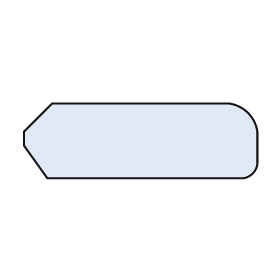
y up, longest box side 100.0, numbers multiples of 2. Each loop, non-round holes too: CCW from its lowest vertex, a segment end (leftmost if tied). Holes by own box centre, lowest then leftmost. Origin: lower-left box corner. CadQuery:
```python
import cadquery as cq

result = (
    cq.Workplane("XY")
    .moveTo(10.0, 0.0)
    .lineTo(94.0, 0.0)
    .threePointArc((98.0, 2.0), (100.0, 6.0))
    .lineTo(100.0, 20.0)
    .threePointArc((96.0, 28.0), (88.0, 32.0))
    .lineTo(12.0, 32.0)
    .lineTo(0.0, 20.0)
    .lineTo(0.0, 14.0)
    .close()
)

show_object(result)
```